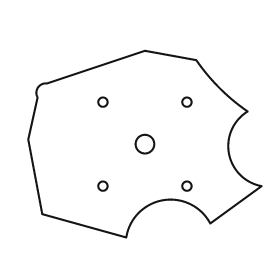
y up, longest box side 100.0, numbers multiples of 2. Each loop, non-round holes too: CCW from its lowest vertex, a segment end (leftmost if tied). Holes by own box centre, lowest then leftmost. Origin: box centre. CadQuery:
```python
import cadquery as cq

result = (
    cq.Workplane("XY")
    .moveTo(-8.0, -40.0)
    .threePointArc((8.0, -24.0), (28.0, -34.0))
    .lineTo(50.0, -18.0)
    .threePointArc((36.0, -4.0), (44.0, 14.0))
    .threePointArc((32.0, 24.0), (22.0, 36.0))
    .lineTo(0.0, 40.0)
    .lineTo(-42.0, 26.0)
    .threePointArc((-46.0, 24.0), (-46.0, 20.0))
    .lineTo(-50.0, 2.0)
    .lineTo(-44.0, -30.0)
    .close()
    .moveTo(-18.0, -18.0)
    .circle(2.0)
    .moveTo(18.0, -18.0)
    .circle(2.0)
    .moveTo(0.0, 0.0)
    .circle(4.0)
    .moveTo(-18.0, 18.0)
    .circle(2.0)
    .moveTo(18.0, 18.0)
    .circle(2.0)
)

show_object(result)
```